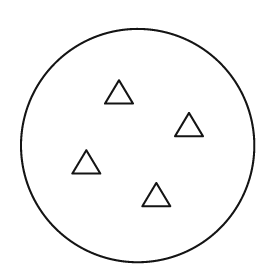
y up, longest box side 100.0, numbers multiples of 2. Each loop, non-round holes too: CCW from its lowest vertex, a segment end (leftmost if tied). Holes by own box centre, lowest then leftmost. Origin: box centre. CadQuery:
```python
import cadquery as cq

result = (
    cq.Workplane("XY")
    .moveTo(0.0, 0.0)
    .circle(50.0)
    .moveTo(2.0, -26.0)
    .lineTo(14.0, -26.0)
    .lineTo(8.0, -16.0)
    .close()
    .moveTo(-28.0, -12.0)
    .lineTo(-16.0, -12.0)
    .lineTo(-22.0, -2.0)
    .close()
    .moveTo(16.0, 4.0)
    .lineTo(28.0, 4.0)
    .lineTo(22.0, 14.0)
    .close()
    .moveTo(-14.0, 18.0)
    .lineTo(-2.0, 18.0)
    .lineTo(-8.0, 28.0)
    .close()
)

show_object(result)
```